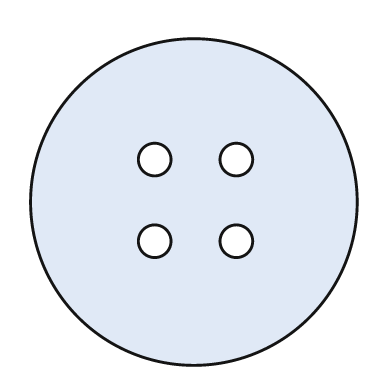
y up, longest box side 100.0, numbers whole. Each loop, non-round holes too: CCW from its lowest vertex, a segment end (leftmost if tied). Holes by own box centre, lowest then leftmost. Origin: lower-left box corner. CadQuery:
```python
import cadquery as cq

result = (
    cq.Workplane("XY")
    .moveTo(50.0, 50.0)
    .circle(50.0)
    .moveTo(38.0, 38.0)
    .circle(5.0)
    .moveTo(63.0, 38.0)
    .circle(5.0)
    .moveTo(38.0, 63.0)
    .circle(5.0)
    .moveTo(63.0, 63.0)
    .circle(5.0)
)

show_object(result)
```